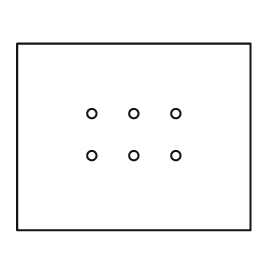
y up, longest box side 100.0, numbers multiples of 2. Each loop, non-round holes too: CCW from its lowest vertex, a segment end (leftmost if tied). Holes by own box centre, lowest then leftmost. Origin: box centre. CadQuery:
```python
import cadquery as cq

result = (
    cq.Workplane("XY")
    .moveTo(-50.0, -40.0)
    .lineTo(50.0, -40.0)
    .lineTo(50.0, 40.0)
    .lineTo(-50.0, 40.0)
    .close()
    .moveTo(-18.0, -8.0)
    .circle(2.0)
    .moveTo(0.0, -8.0)
    .circle(2.0)
    .moveTo(18.0, -8.0)
    .circle(2.0)
    .moveTo(-18.0, 10.0)
    .circle(2.0)
    .moveTo(0.0, 10.0)
    .circle(2.0)
    .moveTo(18.0, 10.0)
    .circle(2.0)
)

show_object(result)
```